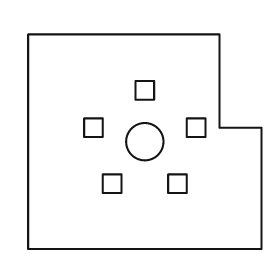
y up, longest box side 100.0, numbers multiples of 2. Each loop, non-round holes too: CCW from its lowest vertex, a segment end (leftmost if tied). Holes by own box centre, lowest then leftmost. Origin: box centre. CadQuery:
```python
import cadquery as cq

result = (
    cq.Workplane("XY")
    .moveTo(-50.0, -46.0)
    .lineTo(50.0, -46.0)
    .lineTo(50.0, 6.0)
    .lineTo(32.0, 6.0)
    .lineTo(32.0, 46.0)
    .lineTo(-50.0, 46.0)
    .close()
    .moveTo(-18.0, -22.0)
    .lineTo(-10.0, -22.0)
    .lineTo(-10.0, -14.0)
    .lineTo(-18.0, -14.0)
    .close()
    .moveTo(10.0, -22.0)
    .lineTo(18.0, -22.0)
    .lineTo(18.0, -14.0)
    .lineTo(10.0, -14.0)
    .close()
    .moveTo(0.0, 0.0)
    .circle(8.0)
    .moveTo(-26.0, 2.0)
    .lineTo(-18.0, 2.0)
    .lineTo(-18.0, 10.0)
    .lineTo(-26.0, 10.0)
    .close()
    .moveTo(18.0, 2.0)
    .lineTo(26.0, 2.0)
    .lineTo(26.0, 10.0)
    .lineTo(18.0, 10.0)
    .close()
    .moveTo(-4.0, 18.0)
    .lineTo(4.0, 18.0)
    .lineTo(4.0, 26.0)
    .lineTo(-4.0, 26.0)
    .close()
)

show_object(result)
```